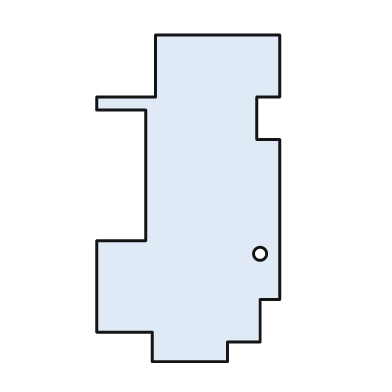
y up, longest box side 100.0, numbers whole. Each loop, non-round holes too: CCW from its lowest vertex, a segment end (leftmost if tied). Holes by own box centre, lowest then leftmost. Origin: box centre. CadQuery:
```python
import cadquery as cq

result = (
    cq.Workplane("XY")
    .moveTo(-11.0, -50.0)
    .lineTo(12.0, -50.0)
    .lineTo(12.0, -44.0)
    .lineTo(22.0, -44.0)
    .lineTo(22.0, -31.0)
    .lineTo(28.0, -31.0)
    .lineTo(28.0, 18.0)
    .lineTo(21.0, 18.0)
    .lineTo(21.0, 31.0)
    .lineTo(28.0, 31.0)
    .lineTo(28.0, 50.0)
    .lineTo(-10.0, 50.0)
    .lineTo(-10.0, 31.0)
    .lineTo(-28.0, 31.0)
    .lineTo(-28.0, 27.0)
    .lineTo(-13.0, 27.0)
    .lineTo(-13.0, -13.0)
    .lineTo(-28.0, -13.0)
    .lineTo(-28.0, -41.0)
    .lineTo(-11.0, -41.0)
    .close()
    .moveTo(22.0, -17.0)
    .circle(2.0)
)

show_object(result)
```